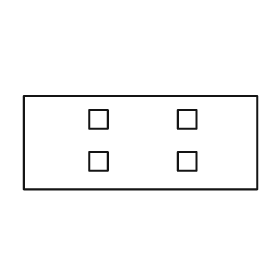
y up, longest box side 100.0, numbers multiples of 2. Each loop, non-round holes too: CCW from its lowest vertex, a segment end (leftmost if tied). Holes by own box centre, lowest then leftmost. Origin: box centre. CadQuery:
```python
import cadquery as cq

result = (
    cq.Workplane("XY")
    .moveTo(-50.0, -20.0)
    .lineTo(50.0, -20.0)
    .lineTo(50.0, 20.0)
    .lineTo(-50.0, 20.0)
    .close()
    .moveTo(-22.0, -12.0)
    .lineTo(-14.0, -12.0)
    .lineTo(-14.0, -4.0)
    .lineTo(-22.0, -4.0)
    .close()
    .moveTo(16.0, -12.0)
    .lineTo(24.0, -12.0)
    .lineTo(24.0, -4.0)
    .lineTo(16.0, -4.0)
    .close()
    .moveTo(-22.0, 6.0)
    .lineTo(-14.0, 6.0)
    .lineTo(-14.0, 14.0)
    .lineTo(-22.0, 14.0)
    .close()
    .moveTo(16.0, 6.0)
    .lineTo(24.0, 6.0)
    .lineTo(24.0, 14.0)
    .lineTo(16.0, 14.0)
    .close()
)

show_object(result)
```